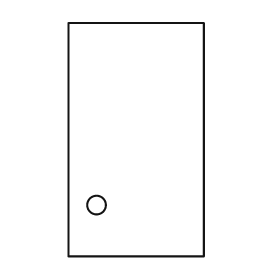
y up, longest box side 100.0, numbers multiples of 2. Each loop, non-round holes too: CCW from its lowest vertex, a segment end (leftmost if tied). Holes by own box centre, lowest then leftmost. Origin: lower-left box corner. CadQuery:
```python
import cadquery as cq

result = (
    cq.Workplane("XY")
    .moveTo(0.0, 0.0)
    .lineTo(58.0, 0.0)
    .lineTo(58.0, 100.0)
    .lineTo(0.0, 100.0)
    .close()
    .moveTo(12.0, 22.0)
    .circle(4.0)
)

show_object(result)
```